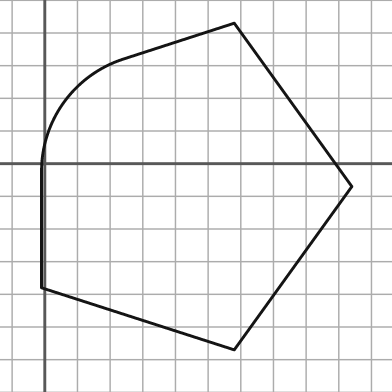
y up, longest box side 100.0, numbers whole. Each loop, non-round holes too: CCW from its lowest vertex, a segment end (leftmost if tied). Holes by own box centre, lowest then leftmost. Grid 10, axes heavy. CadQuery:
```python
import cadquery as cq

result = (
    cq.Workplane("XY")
    .moveTo(58.0, -57.0)
    .lineTo(94.0, -7.0)
    .lineTo(58.0, 43.0)
    .lineTo(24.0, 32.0)
    .threePointArc((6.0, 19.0), (-1.0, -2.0))
    .lineTo(-1.0, -38.0)
    .close()
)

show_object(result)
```